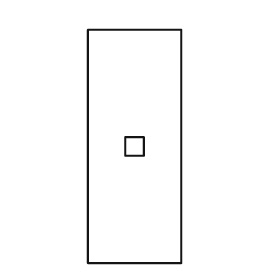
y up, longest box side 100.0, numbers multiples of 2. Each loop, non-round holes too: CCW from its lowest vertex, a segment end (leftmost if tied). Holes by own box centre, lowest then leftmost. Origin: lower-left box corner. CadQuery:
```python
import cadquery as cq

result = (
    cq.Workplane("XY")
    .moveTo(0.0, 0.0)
    .lineTo(40.0, 0.0)
    .lineTo(40.0, 100.0)
    .lineTo(0.0, 100.0)
    .close()
    .moveTo(16.0, 46.0)
    .lineTo(24.0, 46.0)
    .lineTo(24.0, 54.0)
    .lineTo(16.0, 54.0)
    .close()
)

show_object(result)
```